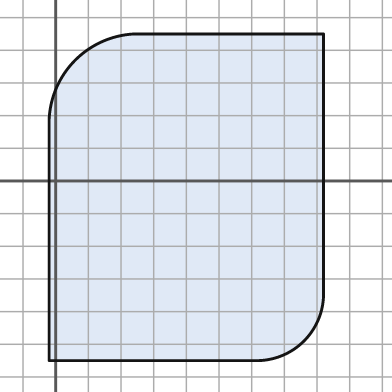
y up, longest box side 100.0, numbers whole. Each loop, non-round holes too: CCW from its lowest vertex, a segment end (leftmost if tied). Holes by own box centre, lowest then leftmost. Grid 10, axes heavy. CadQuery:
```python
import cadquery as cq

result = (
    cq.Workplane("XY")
    .moveTo(-2.0, -55.0)
    .lineTo(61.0, -55.0)
    .threePointArc((76.0, -49.0), (82.0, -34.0))
    .lineTo(82.0, 45.0)
    .lineTo(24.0, 45.0)
    .threePointArc((6.0, 37.0), (-2.0, 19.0))
    .close()
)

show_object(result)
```